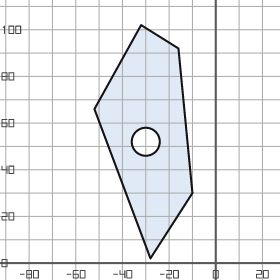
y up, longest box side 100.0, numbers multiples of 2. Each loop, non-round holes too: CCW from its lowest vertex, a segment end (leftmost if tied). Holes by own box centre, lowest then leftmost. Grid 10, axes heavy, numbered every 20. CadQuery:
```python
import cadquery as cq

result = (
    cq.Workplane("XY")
    .moveTo(-28.0, 2.0)
    .lineTo(-10.0, 30.0)
    .lineTo(-16.0, 92.0)
    .lineTo(-32.0, 102.0)
    .lineTo(-52.0, 66.0)
    .close()
    .moveTo(-30.0, 52.0)
    .circle(6.0)
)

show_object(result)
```